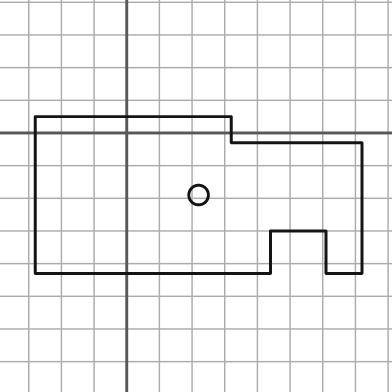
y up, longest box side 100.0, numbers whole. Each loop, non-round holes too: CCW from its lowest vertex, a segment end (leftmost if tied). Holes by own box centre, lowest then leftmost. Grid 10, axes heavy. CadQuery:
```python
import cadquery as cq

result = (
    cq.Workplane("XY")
    .moveTo(-28.0, -43.0)
    .lineTo(44.0, -43.0)
    .lineTo(44.0, -30.0)
    .lineTo(61.0, -30.0)
    .lineTo(61.0, -43.0)
    .lineTo(72.0, -43.0)
    .lineTo(72.0, -3.0)
    .lineTo(32.0, -3.0)
    .lineTo(32.0, 5.0)
    .lineTo(-28.0, 5.0)
    .close()
    .moveTo(22.0, -19.0)
    .circle(3.0)
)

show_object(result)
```